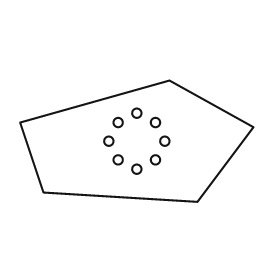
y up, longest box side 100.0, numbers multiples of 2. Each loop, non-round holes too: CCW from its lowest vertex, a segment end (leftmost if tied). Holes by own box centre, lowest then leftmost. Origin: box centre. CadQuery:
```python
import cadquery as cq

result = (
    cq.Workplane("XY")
    .moveTo(26.0, -26.0)
    .lineTo(50.0, 6.0)
    .lineTo(14.0, 26.0)
    .lineTo(-50.0, 8.0)
    .lineTo(-40.0, -22.0)
    .close()
    .moveTo(0.0, -12.0)
    .circle(2.0)
    .moveTo(-8.0, -8.0)
    .circle(2.0)
    .moveTo(8.0, -8.0)
    .circle(2.0)
    .moveTo(-12.0, 0.0)
    .circle(2.0)
    .moveTo(12.0, 0.0)
    .circle(2.0)
    .moveTo(-8.0, 8.0)
    .circle(2.0)
    .moveTo(8.0, 8.0)
    .circle(2.0)
    .moveTo(0.0, 12.0)
    .circle(2.0)
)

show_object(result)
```